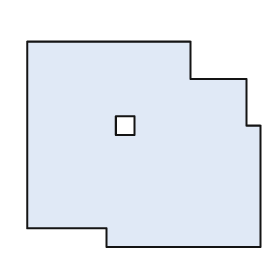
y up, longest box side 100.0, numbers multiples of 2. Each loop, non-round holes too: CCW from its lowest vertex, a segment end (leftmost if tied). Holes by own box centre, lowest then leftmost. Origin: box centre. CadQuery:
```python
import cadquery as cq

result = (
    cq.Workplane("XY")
    .moveTo(-16.0, -44.0)
    .lineTo(50.0, -44.0)
    .lineTo(50.0, 8.0)
    .lineTo(44.0, 8.0)
    .lineTo(44.0, 28.0)
    .lineTo(20.0, 28.0)
    .lineTo(20.0, 44.0)
    .lineTo(-50.0, 44.0)
    .lineTo(-50.0, -36.0)
    .lineTo(-16.0, -36.0)
    .close()
    .moveTo(-12.0, 4.0)
    .lineTo(-4.0, 4.0)
    .lineTo(-4.0, 12.0)
    .lineTo(-12.0, 12.0)
    .close()
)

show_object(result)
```